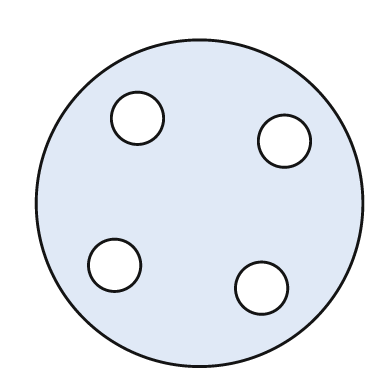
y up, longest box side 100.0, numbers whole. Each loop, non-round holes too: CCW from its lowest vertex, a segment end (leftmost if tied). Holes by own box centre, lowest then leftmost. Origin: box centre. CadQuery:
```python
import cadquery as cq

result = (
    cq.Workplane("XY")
    .moveTo(0.0, 0.0)
    .circle(50.0)
    .moveTo(19.0, -26.0)
    .circle(8.0)
    .moveTo(-26.0, -19.0)
    .circle(8.0)
    .moveTo(26.0, 19.0)
    .circle(8.0)
    .moveTo(-19.0, 26.0)
    .circle(8.0)
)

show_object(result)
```